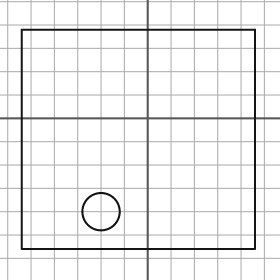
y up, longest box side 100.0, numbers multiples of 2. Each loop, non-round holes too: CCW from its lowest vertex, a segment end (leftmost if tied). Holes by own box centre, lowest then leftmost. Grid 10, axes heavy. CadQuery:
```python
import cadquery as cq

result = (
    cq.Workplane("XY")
    .moveTo(-54.0, -56.0)
    .lineTo(46.0, -56.0)
    .lineTo(46.0, 38.0)
    .lineTo(-54.0, 38.0)
    .close()
    .moveTo(-20.0, -40.0)
    .circle(8.0)
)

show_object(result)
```